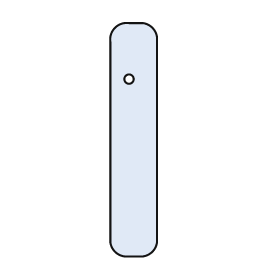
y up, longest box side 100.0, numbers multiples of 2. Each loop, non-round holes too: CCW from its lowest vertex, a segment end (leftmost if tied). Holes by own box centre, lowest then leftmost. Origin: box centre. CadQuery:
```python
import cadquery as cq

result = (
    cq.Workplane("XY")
    .moveTo(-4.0, -50.0)
    .lineTo(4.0, -50.0)
    .threePointArc((8.0, -48.0), (10.0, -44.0))
    .lineTo(10.0, 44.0)
    .threePointArc((8.0, 48.0), (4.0, 50.0))
    .lineTo(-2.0, 50.0)
    .threePointArc((-8.0, 48.0), (-10.0, 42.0))
    .lineTo(-10.0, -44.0)
    .threePointArc((-8.0, -48.0), (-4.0, -50.0))
    .close()
    .moveTo(-2.0, 26.0)
    .circle(2.0)
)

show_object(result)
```